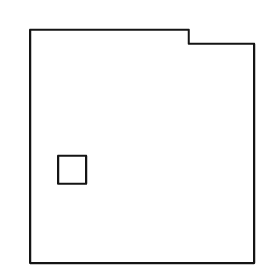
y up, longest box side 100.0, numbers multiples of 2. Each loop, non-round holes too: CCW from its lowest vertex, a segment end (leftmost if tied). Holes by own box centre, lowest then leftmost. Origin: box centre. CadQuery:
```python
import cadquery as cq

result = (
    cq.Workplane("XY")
    .moveTo(-48.0, -50.0)
    .lineTo(48.0, -50.0)
    .lineTo(48.0, 44.0)
    .lineTo(20.0, 44.0)
    .lineTo(20.0, 50.0)
    .lineTo(-48.0, 50.0)
    .close()
    .moveTo(-36.0, -16.0)
    .lineTo(-24.0, -16.0)
    .lineTo(-24.0, -4.0)
    .lineTo(-36.0, -4.0)
    .close()
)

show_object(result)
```